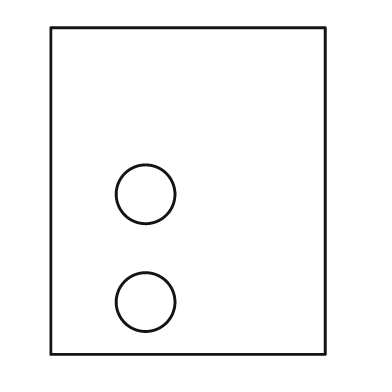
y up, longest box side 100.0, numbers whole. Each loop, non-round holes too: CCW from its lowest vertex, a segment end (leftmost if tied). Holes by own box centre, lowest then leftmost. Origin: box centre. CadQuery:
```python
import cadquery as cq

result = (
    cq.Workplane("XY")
    .moveTo(-42.0, -50.0)
    .lineTo(42.0, -50.0)
    .lineTo(42.0, 50.0)
    .lineTo(-42.0, 50.0)
    .close()
    .moveTo(-13.0, -34.0)
    .circle(9.0)
    .moveTo(-13.0, -1.0)
    .circle(9.0)
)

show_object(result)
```